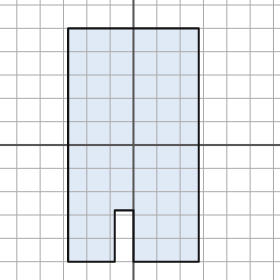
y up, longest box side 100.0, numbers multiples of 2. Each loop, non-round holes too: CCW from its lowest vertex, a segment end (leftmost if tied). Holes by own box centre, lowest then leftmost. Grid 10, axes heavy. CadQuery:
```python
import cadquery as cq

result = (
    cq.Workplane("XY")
    .moveTo(-28.0, -50.0)
    .lineTo(-8.0, -50.0)
    .lineTo(-8.0, -28.0)
    .lineTo(0.0, -28.0)
    .lineTo(0.0, -50.0)
    .lineTo(28.0, -50.0)
    .lineTo(28.0, 50.0)
    .lineTo(-28.0, 50.0)
    .close()
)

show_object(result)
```